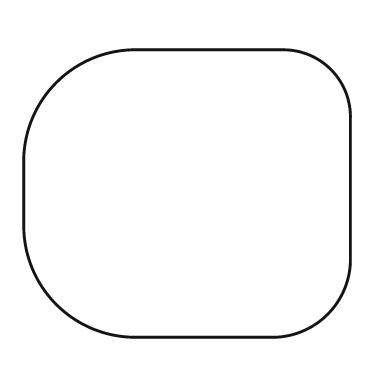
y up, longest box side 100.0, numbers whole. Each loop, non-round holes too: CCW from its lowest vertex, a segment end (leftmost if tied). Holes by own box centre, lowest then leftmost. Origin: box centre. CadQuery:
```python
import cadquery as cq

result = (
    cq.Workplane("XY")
    .moveTo(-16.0, -44.0)
    .lineTo(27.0, -44.0)
    .threePointArc((43.0, -37.0), (50.0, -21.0))
    .lineTo(50.0, 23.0)
    .threePointArc((44.0, 38.0), (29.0, 44.0))
    .lineTo(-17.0, 44.0)
    .threePointArc((-40.0, 34.0), (-50.0, 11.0))
    .lineTo(-50.0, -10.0)
    .threePointArc((-40.0, -34.0), (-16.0, -44.0))
    .close()
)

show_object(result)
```